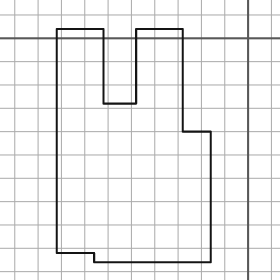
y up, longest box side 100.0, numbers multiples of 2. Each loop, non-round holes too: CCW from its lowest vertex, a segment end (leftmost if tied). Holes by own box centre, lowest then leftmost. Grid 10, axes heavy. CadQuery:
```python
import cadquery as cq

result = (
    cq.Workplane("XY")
    .moveTo(-66.0, -96.0)
    .lineTo(-16.0, -96.0)
    .lineTo(-16.0, -40.0)
    .lineTo(-28.0, -40.0)
    .lineTo(-28.0, 4.0)
    .lineTo(-48.0, 4.0)
    .lineTo(-48.0, -28.0)
    .lineTo(-62.0, -28.0)
    .lineTo(-62.0, 4.0)
    .lineTo(-82.0, 4.0)
    .lineTo(-82.0, -92.0)
    .lineTo(-66.0, -92.0)
    .close()
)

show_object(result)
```